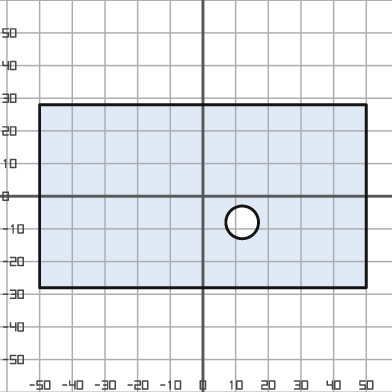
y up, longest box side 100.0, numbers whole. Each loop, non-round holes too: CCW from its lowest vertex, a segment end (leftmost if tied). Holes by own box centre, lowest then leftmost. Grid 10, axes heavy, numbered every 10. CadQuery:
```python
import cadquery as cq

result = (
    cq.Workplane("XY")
    .moveTo(-50.0, -28.0)
    .lineTo(50.0, -28.0)
    .lineTo(50.0, 28.0)
    .lineTo(-50.0, 28.0)
    .close()
    .moveTo(12.0, -8.0)
    .circle(5.0)
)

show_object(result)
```